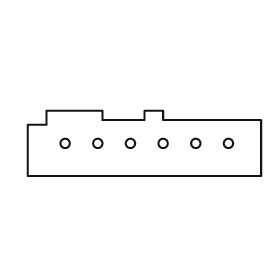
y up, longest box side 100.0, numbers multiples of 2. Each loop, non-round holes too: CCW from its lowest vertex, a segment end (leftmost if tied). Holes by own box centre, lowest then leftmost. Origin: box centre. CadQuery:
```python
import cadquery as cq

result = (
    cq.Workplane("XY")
    .moveTo(-50.0, -14.0)
    .lineTo(50.0, -14.0)
    .lineTo(50.0, 10.0)
    .lineTo(8.0, 10.0)
    .lineTo(8.0, 14.0)
    .lineTo(0.0, 14.0)
    .lineTo(0.0, 10.0)
    .lineTo(-18.0, 10.0)
    .lineTo(-18.0, 14.0)
    .lineTo(-42.0, 14.0)
    .lineTo(-42.0, 8.0)
    .lineTo(-50.0, 8.0)
    .close()
    .moveTo(-34.0, 0.0)
    .circle(2.0)
    .moveTo(-20.0, 0.0)
    .circle(2.0)
    .moveTo(-6.0, 0.0)
    .circle(2.0)
    .moveTo(8.0, 0.0)
    .circle(2.0)
    .moveTo(22.0, 0.0)
    .circle(2.0)
    .moveTo(36.0, 0.0)
    .circle(2.0)
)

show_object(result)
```